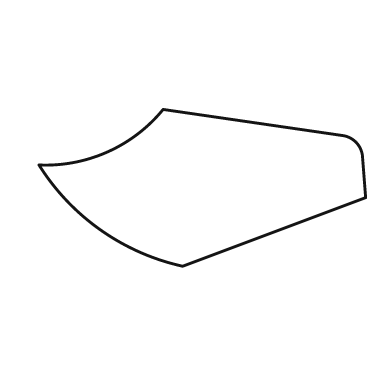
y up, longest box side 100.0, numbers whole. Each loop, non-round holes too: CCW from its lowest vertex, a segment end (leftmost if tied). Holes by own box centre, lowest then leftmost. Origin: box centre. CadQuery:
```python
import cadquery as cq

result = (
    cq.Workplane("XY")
    .moveTo(-6.0, -24.0)
    .lineTo(50.0, -3.0)
    .lineTo(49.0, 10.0)
    .threePointArc((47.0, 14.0), (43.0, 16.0))
    .lineTo(-12.0, 24.0)
    .threePointArc((-29.0, 11.0), (-50.0, 7.0))
    .threePointArc((-31.0, -13.0), (-6.0, -24.0))
    .close()
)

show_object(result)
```